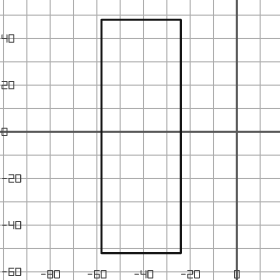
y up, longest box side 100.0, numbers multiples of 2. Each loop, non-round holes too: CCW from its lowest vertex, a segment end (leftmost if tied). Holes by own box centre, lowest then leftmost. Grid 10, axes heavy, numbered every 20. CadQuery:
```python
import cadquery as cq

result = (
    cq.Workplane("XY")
    .moveTo(-58.0, -52.0)
    .lineTo(-24.0, -52.0)
    .lineTo(-24.0, 48.0)
    .lineTo(-58.0, 48.0)
    .close()
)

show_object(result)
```